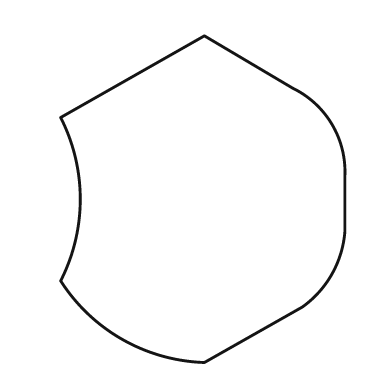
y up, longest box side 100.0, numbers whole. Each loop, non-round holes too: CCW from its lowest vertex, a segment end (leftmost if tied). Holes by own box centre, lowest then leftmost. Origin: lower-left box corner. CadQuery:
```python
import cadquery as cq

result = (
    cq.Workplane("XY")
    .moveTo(44.0, 0.0)
    .lineTo(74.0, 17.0)
    .threePointArc((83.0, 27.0), (87.0, 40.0))
    .lineTo(87.0, 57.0)
    .threePointArc((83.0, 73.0), (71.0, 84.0))
    .lineTo(44.0, 100.0)
    .lineTo(0.0, 75.0)
    .threePointArc((6.0, 50.0), (0.0, 25.0))
    .threePointArc((19.0, 7.0), (44.0, 0.0))
    .close()
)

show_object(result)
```